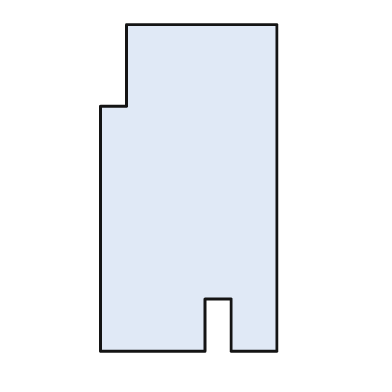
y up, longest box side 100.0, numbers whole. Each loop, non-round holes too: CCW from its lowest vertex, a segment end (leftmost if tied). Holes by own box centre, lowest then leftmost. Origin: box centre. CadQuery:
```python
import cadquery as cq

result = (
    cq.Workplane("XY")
    .moveTo(-27.0, -50.0)
    .lineTo(5.0, -50.0)
    .lineTo(5.0, -34.0)
    .lineTo(13.0, -34.0)
    .lineTo(13.0, -50.0)
    .lineTo(27.0, -50.0)
    .lineTo(27.0, 50.0)
    .lineTo(-19.0, 50.0)
    .lineTo(-19.0, 25.0)
    .lineTo(-27.0, 25.0)
    .close()
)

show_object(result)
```